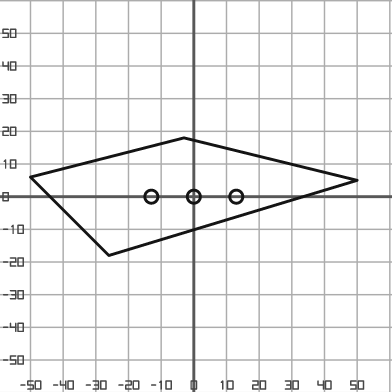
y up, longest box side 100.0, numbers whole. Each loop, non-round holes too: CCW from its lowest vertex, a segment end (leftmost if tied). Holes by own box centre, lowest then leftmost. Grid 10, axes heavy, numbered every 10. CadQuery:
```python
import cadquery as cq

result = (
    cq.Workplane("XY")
    .moveTo(-26.0, -18.0)
    .lineTo(50.0, 5.0)
    .lineTo(-3.0, 18.0)
    .lineTo(-50.0, 6.0)
    .close()
    .moveTo(-13.0, 0.0)
    .circle(2.0)
    .moveTo(0.0, 0.0)
    .circle(2.0)
    .moveTo(13.0, 0.0)
    .circle(2.0)
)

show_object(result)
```